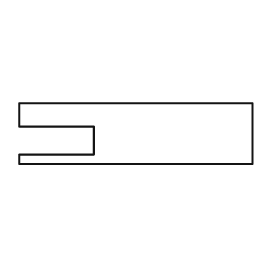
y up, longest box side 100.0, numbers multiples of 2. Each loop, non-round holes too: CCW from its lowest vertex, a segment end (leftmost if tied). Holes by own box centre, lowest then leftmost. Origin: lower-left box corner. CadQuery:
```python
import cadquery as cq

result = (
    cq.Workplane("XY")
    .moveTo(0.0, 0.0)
    .lineTo(100.0, 0.0)
    .lineTo(100.0, 26.0)
    .lineTo(0.0, 26.0)
    .lineTo(0.0, 16.0)
    .lineTo(32.0, 16.0)
    .lineTo(32.0, 4.0)
    .lineTo(0.0, 4.0)
    .close()
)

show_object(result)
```